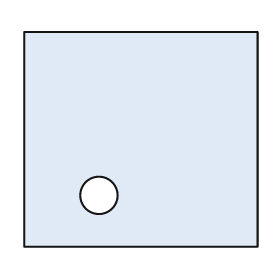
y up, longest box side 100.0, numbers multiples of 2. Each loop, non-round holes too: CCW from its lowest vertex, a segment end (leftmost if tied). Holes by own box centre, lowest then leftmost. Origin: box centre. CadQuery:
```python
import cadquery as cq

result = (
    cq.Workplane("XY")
    .moveTo(-50.0, -46.0)
    .lineTo(50.0, -46.0)
    .lineTo(50.0, 46.0)
    .lineTo(-50.0, 46.0)
    .close()
    .moveTo(-18.0, -24.0)
    .circle(8.0)
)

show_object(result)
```